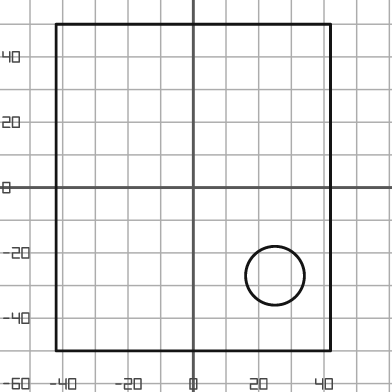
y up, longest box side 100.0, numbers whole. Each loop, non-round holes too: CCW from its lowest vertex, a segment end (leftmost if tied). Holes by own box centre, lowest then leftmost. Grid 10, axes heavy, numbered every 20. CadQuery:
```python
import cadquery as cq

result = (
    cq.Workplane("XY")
    .moveTo(-42.0, -50.0)
    .lineTo(42.0, -50.0)
    .lineTo(42.0, 50.0)
    .lineTo(-42.0, 50.0)
    .close()
    .moveTo(25.0, -27.0)
    .circle(9.0)
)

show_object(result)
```